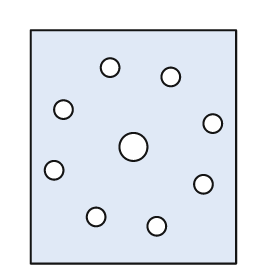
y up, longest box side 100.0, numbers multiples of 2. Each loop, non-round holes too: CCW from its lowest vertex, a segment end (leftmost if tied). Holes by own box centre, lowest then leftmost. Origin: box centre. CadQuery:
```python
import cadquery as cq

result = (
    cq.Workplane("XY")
    .moveTo(-44.0, -50.0)
    .lineTo(44.0, -50.0)
    .lineTo(44.0, 50.0)
    .lineTo(-44.0, 50.0)
    .close()
    .moveTo(10.0, -34.0)
    .circle(4.0)
    .moveTo(-16.0, -30.0)
    .circle(4.0)
    .moveTo(30.0, -16.0)
    .circle(4.0)
    .moveTo(-34.0, -10.0)
    .circle(4.0)
    .moveTo(0.0, 0.0)
    .circle(6.0)
    .moveTo(34.0, 10.0)
    .circle(4.0)
    .moveTo(-30.0, 16.0)
    .circle(4.0)
    .moveTo(16.0, 30.0)
    .circle(4.0)
    .moveTo(-10.0, 34.0)
    .circle(4.0)
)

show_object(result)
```